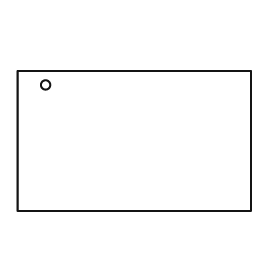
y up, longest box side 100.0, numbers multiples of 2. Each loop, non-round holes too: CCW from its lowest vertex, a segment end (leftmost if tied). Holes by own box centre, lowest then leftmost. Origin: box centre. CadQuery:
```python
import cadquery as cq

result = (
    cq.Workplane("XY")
    .moveTo(-50.0, -30.0)
    .lineTo(50.0, -30.0)
    .lineTo(50.0, 30.0)
    .lineTo(-50.0, 30.0)
    .close()
    .moveTo(-38.0, 24.0)
    .circle(2.0)
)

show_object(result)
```